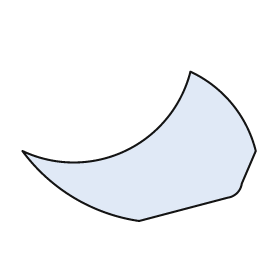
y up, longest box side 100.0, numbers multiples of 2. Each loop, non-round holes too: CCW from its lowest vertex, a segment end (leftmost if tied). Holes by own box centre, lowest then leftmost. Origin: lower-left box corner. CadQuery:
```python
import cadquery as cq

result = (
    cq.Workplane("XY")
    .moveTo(50.0, 0.0)
    .lineTo(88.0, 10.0)
    .threePointArc((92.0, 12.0), (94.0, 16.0))
    .lineTo(100.0, 30.0)
    .threePointArc((90.0, 50.0), (72.0, 64.0))
    .threePointArc((44.0, 30.0), (0.0, 30.0))
    .threePointArc((22.0, 10.0), (50.0, 0.0))
    .close()
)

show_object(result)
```